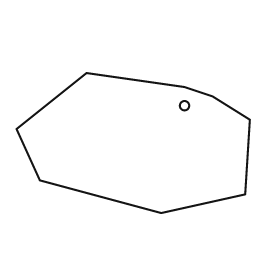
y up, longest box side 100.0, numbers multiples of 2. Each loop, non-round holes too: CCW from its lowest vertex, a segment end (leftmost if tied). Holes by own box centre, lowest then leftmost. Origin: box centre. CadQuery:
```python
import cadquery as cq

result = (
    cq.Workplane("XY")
    .moveTo(12.0, -30.0)
    .lineTo(48.0, -22.0)
    .lineTo(50.0, 10.0)
    .lineTo(34.0, 20.0)
    .lineTo(22.0, 24.0)
    .lineTo(-20.0, 30.0)
    .lineTo(-50.0, 6.0)
    .lineTo(-40.0, -16.0)
    .close()
    .moveTo(22.0, 16.0)
    .circle(2.0)
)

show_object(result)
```